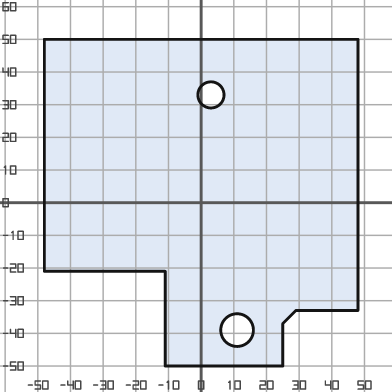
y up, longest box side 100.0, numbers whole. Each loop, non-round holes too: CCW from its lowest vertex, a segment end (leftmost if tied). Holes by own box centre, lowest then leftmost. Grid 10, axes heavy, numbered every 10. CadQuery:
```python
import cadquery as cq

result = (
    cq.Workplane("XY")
    .moveTo(-11.0, -50.0)
    .lineTo(25.0, -50.0)
    .lineTo(25.0, -37.0)
    .lineTo(29.0, -33.0)
    .lineTo(48.0, -33.0)
    .lineTo(48.0, 50.0)
    .lineTo(-48.0, 50.0)
    .lineTo(-48.0, -21.0)
    .lineTo(-11.0, -21.0)
    .close()
    .moveTo(11.0, -39.0)
    .circle(5.0)
    .moveTo(3.0, 33.0)
    .circle(4.0)
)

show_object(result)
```